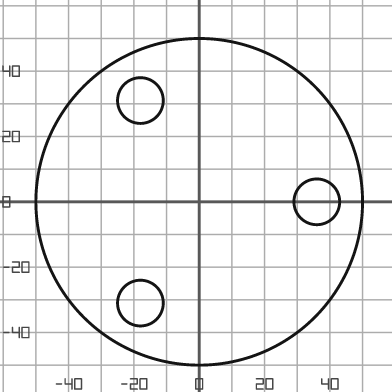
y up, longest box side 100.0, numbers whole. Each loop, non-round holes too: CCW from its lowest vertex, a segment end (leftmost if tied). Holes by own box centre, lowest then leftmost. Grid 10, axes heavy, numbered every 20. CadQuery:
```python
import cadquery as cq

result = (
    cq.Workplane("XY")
    .moveTo(0.0, 0.0)
    .circle(50.0)
    .moveTo(-18.0, -31.0)
    .circle(7.0)
    .moveTo(36.0, 0.0)
    .circle(7.0)
    .moveTo(-18.0, 31.0)
    .circle(7.0)
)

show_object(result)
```